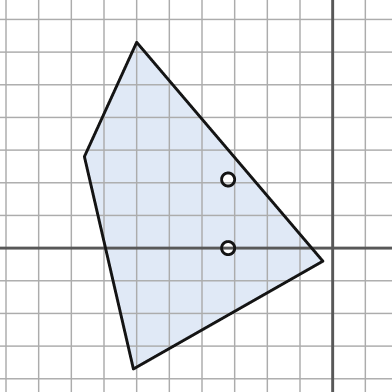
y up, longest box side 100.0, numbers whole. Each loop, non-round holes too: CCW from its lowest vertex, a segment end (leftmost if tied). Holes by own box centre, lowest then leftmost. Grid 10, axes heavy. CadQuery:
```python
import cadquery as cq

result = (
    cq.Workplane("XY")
    .moveTo(-61.0, -37.0)
    .lineTo(-3.0, -4.0)
    .lineTo(-60.0, 63.0)
    .lineTo(-76.0, 28.0)
    .close()
    .moveTo(-32.0, 0.0)
    .circle(2.0)
    .moveTo(-32.0, 21.0)
    .circle(2.0)
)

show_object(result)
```